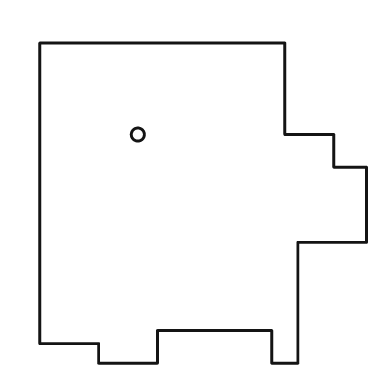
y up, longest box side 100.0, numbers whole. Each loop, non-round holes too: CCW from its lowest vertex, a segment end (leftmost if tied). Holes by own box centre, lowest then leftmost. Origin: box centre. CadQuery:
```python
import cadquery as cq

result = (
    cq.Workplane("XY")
    .moveTo(-32.0, -49.0)
    .lineTo(-14.0, -49.0)
    .lineTo(-14.0, -39.0)
    .lineTo(21.0, -39.0)
    .lineTo(21.0, -49.0)
    .lineTo(29.0, -49.0)
    .lineTo(29.0, -12.0)
    .lineTo(50.0, -12.0)
    .lineTo(50.0, 11.0)
    .lineTo(40.0, 11.0)
    .lineTo(40.0, 21.0)
    .lineTo(25.0, 21.0)
    .lineTo(25.0, 49.0)
    .lineTo(-50.0, 49.0)
    .lineTo(-50.0, -43.0)
    .lineTo(-32.0, -43.0)
    .close()
    .moveTo(-20.0, 21.0)
    .circle(2.0)
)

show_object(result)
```